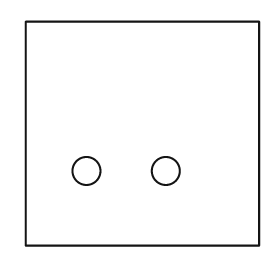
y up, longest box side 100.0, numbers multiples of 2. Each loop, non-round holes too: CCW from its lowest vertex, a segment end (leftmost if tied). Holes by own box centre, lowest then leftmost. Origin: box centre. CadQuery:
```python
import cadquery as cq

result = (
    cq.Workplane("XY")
    .moveTo(-50.0, -48.0)
    .lineTo(50.0, -48.0)
    .lineTo(50.0, 48.0)
    .lineTo(-50.0, 48.0)
    .close()
    .moveTo(-24.0, -16.0)
    .circle(6.0)
    .moveTo(10.0, -16.0)
    .circle(6.0)
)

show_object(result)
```